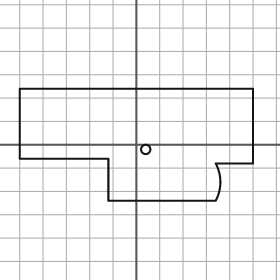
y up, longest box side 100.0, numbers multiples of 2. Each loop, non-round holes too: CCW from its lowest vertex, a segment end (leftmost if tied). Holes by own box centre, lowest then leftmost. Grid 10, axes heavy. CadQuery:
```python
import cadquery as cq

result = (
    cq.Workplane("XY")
    .moveTo(-12.0, -24.0)
    .lineTo(34.0, -24.0)
    .threePointArc((36.0, -16.0), (34.0, -8.0))
    .lineTo(50.0, -8.0)
    .lineTo(50.0, 24.0)
    .lineTo(-50.0, 24.0)
    .lineTo(-50.0, -6.0)
    .lineTo(-12.0, -6.0)
    .close()
    .moveTo(4.0, -2.0)
    .circle(2.0)
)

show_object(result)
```